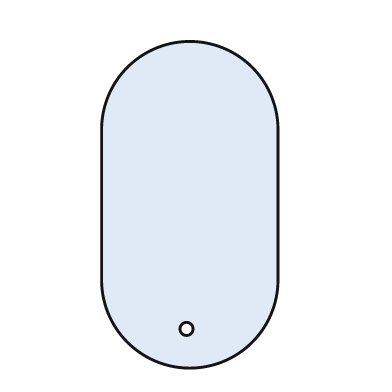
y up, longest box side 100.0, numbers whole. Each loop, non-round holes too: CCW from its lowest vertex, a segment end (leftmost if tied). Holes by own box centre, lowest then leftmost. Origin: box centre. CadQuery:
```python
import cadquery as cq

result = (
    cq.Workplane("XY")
    .moveTo(-27.0, -23.0)
    .threePointArc((0.0, -50.0), (27.0, -23.0))
    .lineTo(27.0, 23.0)
    .threePointArc((0.0, 50.0), (-27.0, 23.0))
    .close()
    .moveTo(-1.0, -38.0)
    .circle(2.0)
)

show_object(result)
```